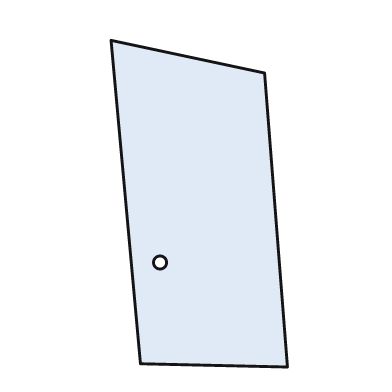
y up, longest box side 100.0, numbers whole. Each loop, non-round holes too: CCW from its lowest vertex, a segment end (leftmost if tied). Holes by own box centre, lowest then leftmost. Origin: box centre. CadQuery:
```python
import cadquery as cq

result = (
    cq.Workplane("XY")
    .moveTo(27.0, -50.0)
    .lineTo(20.0, 40.0)
    .lineTo(-27.0, 50.0)
    .lineTo(-18.0, -49.0)
    .close()
    .moveTo(-12.0, -18.0)
    .circle(2.0)
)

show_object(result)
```